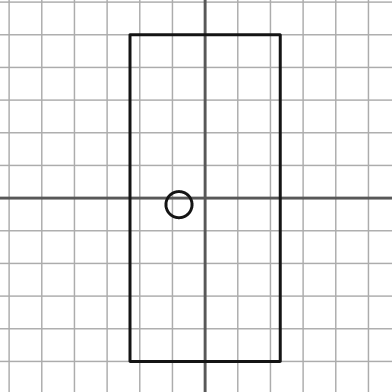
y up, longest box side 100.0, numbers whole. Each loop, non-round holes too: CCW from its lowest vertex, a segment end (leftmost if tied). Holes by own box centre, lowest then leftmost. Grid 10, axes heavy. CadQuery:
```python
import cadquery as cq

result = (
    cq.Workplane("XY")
    .moveTo(-23.0, -50.0)
    .lineTo(23.0, -50.0)
    .lineTo(23.0, 50.0)
    .lineTo(-23.0, 50.0)
    .close()
    .moveTo(-8.0, -2.0)
    .circle(4.0)
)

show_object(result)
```